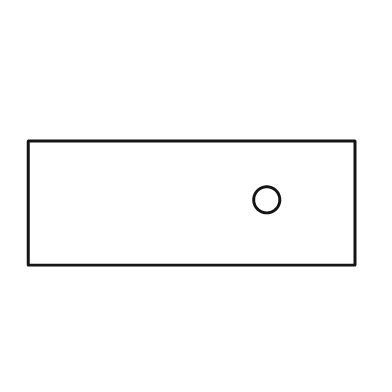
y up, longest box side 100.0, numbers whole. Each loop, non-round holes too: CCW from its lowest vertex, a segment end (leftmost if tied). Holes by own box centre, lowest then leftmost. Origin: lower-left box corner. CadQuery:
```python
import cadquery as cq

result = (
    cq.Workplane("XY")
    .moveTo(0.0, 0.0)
    .lineTo(100.0, 0.0)
    .lineTo(100.0, 38.0)
    .lineTo(0.0, 38.0)
    .close()
    .moveTo(73.0, 20.0)
    .circle(4.0)
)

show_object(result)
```